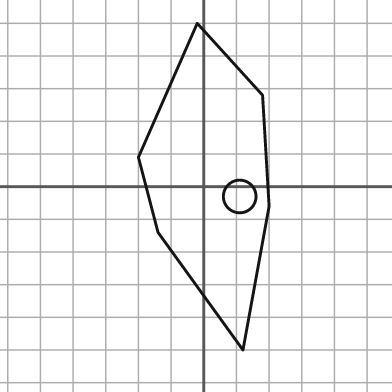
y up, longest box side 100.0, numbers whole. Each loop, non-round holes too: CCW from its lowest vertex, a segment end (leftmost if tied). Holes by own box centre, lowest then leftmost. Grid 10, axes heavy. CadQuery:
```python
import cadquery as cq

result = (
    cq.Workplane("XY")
    .moveTo(12.0, -50.0)
    .lineTo(20.0, -6.0)
    .lineTo(18.0, 28.0)
    .lineTo(-2.0, 50.0)
    .lineTo(-20.0, 9.0)
    .lineTo(-14.0, -14.0)
    .close()
    .moveTo(11.0, -3.0)
    .circle(5.0)
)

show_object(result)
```